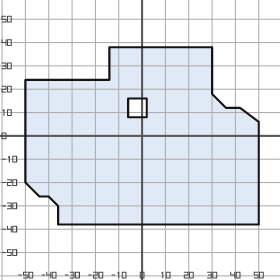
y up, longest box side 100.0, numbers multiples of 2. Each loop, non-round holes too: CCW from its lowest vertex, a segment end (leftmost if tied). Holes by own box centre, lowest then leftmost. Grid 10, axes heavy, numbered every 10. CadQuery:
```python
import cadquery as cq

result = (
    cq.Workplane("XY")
    .moveTo(-36.0, -38.0)
    .lineTo(50.0, -38.0)
    .lineTo(50.0, 6.0)
    .lineTo(42.0, 12.0)
    .lineTo(36.0, 12.0)
    .lineTo(30.0, 18.0)
    .lineTo(30.0, 38.0)
    .lineTo(-14.0, 38.0)
    .lineTo(-14.0, 24.0)
    .lineTo(-50.0, 24.0)
    .lineTo(-50.0, -20.0)
    .lineTo(-44.0, -26.0)
    .lineTo(-40.0, -26.0)
    .lineTo(-36.0, -30.0)
    .close()
    .moveTo(-6.0, 8.0)
    .lineTo(2.0, 8.0)
    .lineTo(2.0, 16.0)
    .lineTo(-6.0, 16.0)
    .close()
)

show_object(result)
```